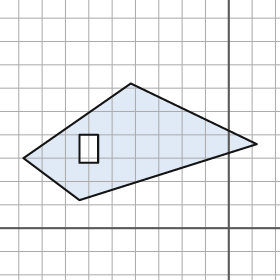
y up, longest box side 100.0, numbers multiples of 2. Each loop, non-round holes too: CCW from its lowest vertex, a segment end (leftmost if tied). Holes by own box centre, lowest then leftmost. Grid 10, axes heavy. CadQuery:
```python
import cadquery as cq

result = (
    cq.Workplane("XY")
    .moveTo(-64.0, 12.0)
    .lineTo(12.0, 36.0)
    .lineTo(-42.0, 62.0)
    .lineTo(-88.0, 30.0)
    .close()
    .moveTo(-64.0, 28.0)
    .lineTo(-56.0, 28.0)
    .lineTo(-56.0, 40.0)
    .lineTo(-64.0, 40.0)
    .close()
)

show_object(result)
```